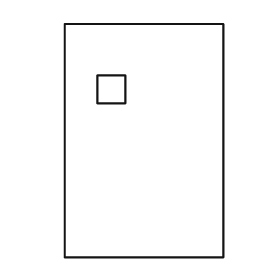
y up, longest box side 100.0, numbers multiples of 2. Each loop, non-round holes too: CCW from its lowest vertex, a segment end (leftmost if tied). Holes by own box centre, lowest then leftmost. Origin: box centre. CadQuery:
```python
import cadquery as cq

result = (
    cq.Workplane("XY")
    .moveTo(-34.0, -50.0)
    .lineTo(34.0, -50.0)
    .lineTo(34.0, 50.0)
    .lineTo(-34.0, 50.0)
    .close()
    .moveTo(-20.0, 16.0)
    .lineTo(-8.0, 16.0)
    .lineTo(-8.0, 28.0)
    .lineTo(-20.0, 28.0)
    .close()
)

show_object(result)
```